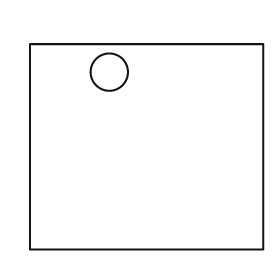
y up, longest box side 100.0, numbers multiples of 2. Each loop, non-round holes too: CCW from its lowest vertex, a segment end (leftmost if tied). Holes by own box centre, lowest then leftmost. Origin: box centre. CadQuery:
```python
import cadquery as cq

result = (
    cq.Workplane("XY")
    .moveTo(-50.0, -44.0)
    .lineTo(50.0, -44.0)
    .lineTo(50.0, 44.0)
    .lineTo(-50.0, 44.0)
    .close()
    .moveTo(-16.0, 32.0)
    .circle(8.0)
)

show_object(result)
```